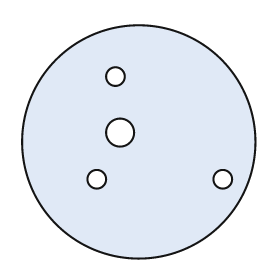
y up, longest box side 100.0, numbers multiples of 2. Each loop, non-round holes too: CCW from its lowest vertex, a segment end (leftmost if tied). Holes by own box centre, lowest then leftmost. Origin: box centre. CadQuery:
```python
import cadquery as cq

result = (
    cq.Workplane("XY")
    .moveTo(0.0, 0.0)
    .circle(50.0)
    .moveTo(-18.0, -16.0)
    .circle(4.0)
    .moveTo(36.0, -16.0)
    .circle(4.0)
    .moveTo(-8.0, 4.0)
    .circle(6.0)
    .moveTo(-10.0, 28.0)
    .circle(4.0)
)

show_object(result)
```